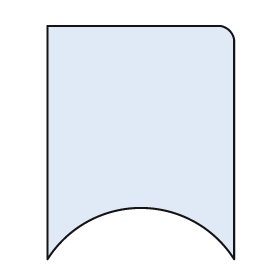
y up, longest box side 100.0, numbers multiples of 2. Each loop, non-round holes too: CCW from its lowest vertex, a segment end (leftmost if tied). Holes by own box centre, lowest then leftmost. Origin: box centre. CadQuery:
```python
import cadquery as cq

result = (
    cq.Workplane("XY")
    .moveTo(-40.0, -50.0)
    .threePointArc((0.0, -28.0), (40.0, -50.0))
    .lineTo(40.0, 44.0)
    .threePointArc((38.0, 48.0), (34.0, 50.0))
    .lineTo(-40.0, 50.0)
    .close()
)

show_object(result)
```